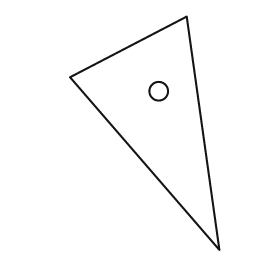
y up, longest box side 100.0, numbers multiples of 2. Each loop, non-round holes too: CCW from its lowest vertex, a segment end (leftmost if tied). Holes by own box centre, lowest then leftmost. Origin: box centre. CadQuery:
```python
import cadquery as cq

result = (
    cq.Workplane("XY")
    .moveTo(32.0, -50.0)
    .lineTo(18.0, 50.0)
    .lineTo(-32.0, 24.0)
    .close()
    .moveTo(6.0, 18.0)
    .circle(4.0)
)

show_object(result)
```